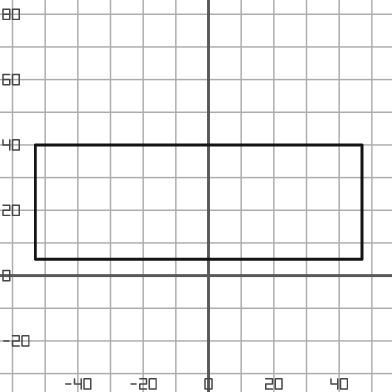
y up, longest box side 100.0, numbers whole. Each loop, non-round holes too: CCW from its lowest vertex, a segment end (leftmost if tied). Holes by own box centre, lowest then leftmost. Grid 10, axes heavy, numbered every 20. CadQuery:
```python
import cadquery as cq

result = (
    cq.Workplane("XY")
    .moveTo(-53.0, 5.0)
    .lineTo(47.0, 5.0)
    .lineTo(47.0, 40.0)
    .lineTo(-53.0, 40.0)
    .close()
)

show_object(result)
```